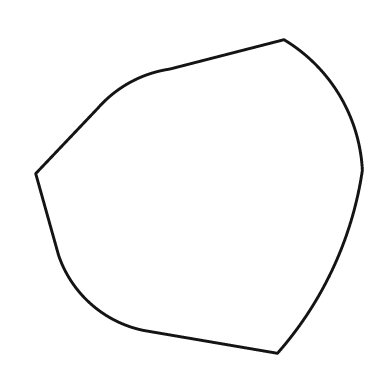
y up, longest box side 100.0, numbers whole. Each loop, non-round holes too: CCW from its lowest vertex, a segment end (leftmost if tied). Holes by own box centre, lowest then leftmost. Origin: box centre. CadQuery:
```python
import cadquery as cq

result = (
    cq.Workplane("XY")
    .moveTo(24.0, -48.0)
    .threePointArc((41.0, -22.0), (50.0, 8.0))
    .threePointArc((43.0, 31.0), (26.0, 48.0))
    .lineTo(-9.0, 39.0)
    .threePointArc((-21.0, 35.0), (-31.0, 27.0))
    .lineTo(-50.0, 7.0)
    .lineTo(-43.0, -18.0)
    .threePointArc((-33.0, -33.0), (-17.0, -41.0))
    .close()
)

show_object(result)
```